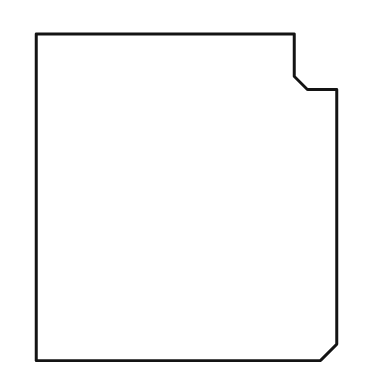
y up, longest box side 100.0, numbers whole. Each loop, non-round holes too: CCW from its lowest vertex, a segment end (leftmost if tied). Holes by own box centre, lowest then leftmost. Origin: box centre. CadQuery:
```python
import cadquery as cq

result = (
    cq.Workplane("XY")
    .moveTo(-46.0, -50.0)
    .lineTo(41.0, -50.0)
    .lineTo(46.0, -45.0)
    .lineTo(46.0, 33.0)
    .lineTo(37.0, 33.0)
    .lineTo(33.0, 37.0)
    .lineTo(33.0, 50.0)
    .lineTo(-46.0, 50.0)
    .close()
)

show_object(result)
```